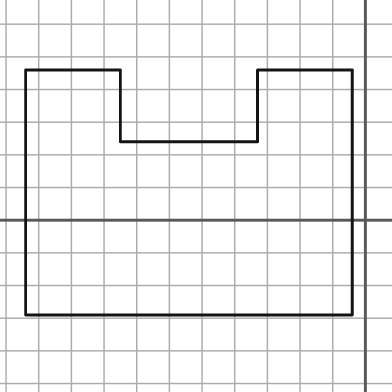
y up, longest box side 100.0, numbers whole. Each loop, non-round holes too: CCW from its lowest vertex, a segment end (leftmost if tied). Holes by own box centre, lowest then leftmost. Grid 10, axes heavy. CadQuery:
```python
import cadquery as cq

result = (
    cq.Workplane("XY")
    .moveTo(-104.0, -29.0)
    .lineTo(-4.0, -29.0)
    .lineTo(-4.0, 46.0)
    .lineTo(-33.0, 46.0)
    .lineTo(-33.0, 24.0)
    .lineTo(-75.0, 24.0)
    .lineTo(-75.0, 46.0)
    .lineTo(-104.0, 46.0)
    .close()
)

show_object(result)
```